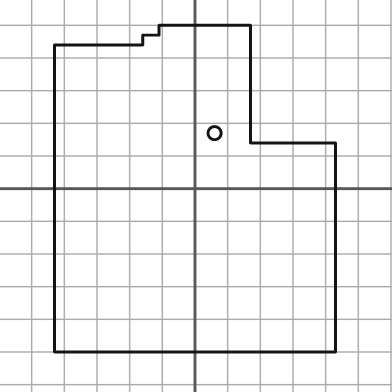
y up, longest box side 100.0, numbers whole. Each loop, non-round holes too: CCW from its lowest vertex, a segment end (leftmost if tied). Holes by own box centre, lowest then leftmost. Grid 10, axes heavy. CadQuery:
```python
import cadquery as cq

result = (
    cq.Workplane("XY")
    .moveTo(-43.0, -50.0)
    .lineTo(43.0, -50.0)
    .lineTo(43.0, 14.0)
    .lineTo(17.0, 14.0)
    .lineTo(17.0, 50.0)
    .lineTo(-11.0, 50.0)
    .lineTo(-11.0, 47.0)
    .lineTo(-16.0, 47.0)
    .lineTo(-16.0, 44.0)
    .lineTo(-43.0, 44.0)
    .close()
    .moveTo(6.0, 17.0)
    .circle(2.0)
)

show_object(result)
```